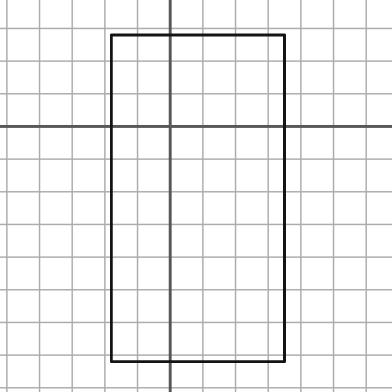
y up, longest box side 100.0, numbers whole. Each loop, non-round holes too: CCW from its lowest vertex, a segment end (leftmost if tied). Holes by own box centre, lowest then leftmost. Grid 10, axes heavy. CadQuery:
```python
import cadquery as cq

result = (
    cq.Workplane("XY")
    .moveTo(-18.0, -72.0)
    .lineTo(35.0, -72.0)
    .lineTo(35.0, 28.0)
    .lineTo(-18.0, 28.0)
    .close()
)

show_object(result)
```